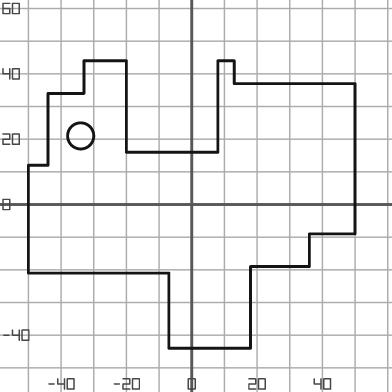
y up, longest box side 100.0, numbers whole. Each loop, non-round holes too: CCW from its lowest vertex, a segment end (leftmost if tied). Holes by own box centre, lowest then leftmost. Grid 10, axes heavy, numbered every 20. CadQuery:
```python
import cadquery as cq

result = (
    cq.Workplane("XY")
    .moveTo(-7.0, -44.0)
    .lineTo(18.0, -44.0)
    .lineTo(18.0, -19.0)
    .lineTo(36.0, -19.0)
    .lineTo(36.0, -9.0)
    .lineTo(50.0, -9.0)
    .lineTo(50.0, 37.0)
    .lineTo(13.0, 37.0)
    .lineTo(13.0, 44.0)
    .lineTo(8.0, 44.0)
    .lineTo(8.0, 16.0)
    .lineTo(-20.0, 16.0)
    .lineTo(-20.0, 44.0)
    .lineTo(-33.0, 44.0)
    .lineTo(-33.0, 34.0)
    .lineTo(-44.0, 34.0)
    .lineTo(-44.0, 12.0)
    .lineTo(-50.0, 12.0)
    .lineTo(-50.0, -21.0)
    .lineTo(-7.0, -21.0)
    .close()
    .moveTo(-34.0, 21.0)
    .circle(4.0)
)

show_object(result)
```